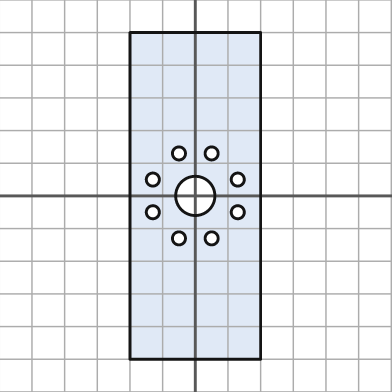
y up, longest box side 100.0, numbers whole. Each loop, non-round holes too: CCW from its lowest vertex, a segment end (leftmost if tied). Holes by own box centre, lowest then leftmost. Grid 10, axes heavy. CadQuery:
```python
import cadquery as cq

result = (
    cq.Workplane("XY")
    .moveTo(-20.0, -50.0)
    .lineTo(20.0, -50.0)
    .lineTo(20.0, 50.0)
    .lineTo(-20.0, 50.0)
    .close()
    .moveTo(-5.0, -13.0)
    .circle(2.0)
    .moveTo(5.0, -13.0)
    .circle(2.0)
    .moveTo(-13.0, -5.0)
    .circle(2.0)
    .moveTo(13.0, -5.0)
    .circle(2.0)
    .moveTo(0.0, 0.0)
    .circle(6.0)
    .moveTo(-13.0, 5.0)
    .circle(2.0)
    .moveTo(13.0, 5.0)
    .circle(2.0)
    .moveTo(-5.0, 13.0)
    .circle(2.0)
    .moveTo(5.0, 13.0)
    .circle(2.0)
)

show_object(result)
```